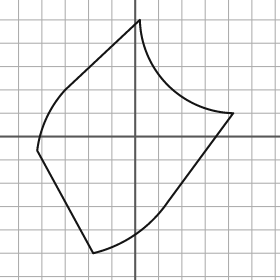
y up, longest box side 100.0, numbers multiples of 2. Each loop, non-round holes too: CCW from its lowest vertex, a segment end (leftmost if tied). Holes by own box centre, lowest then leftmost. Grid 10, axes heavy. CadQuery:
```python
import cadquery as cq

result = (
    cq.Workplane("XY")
    .moveTo(-18.0, -50.0)
    .threePointArc((0.0, -42.0), (14.0, -28.0))
    .lineTo(42.0, 10.0)
    .threePointArc((14.0, 22.0), (2.0, 50.0))
    .lineTo(-30.0, 20.0)
    .threePointArc((-38.0, 8.0), (-42.0, -6.0))
    .close()
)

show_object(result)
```